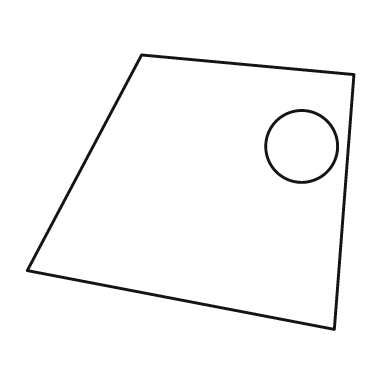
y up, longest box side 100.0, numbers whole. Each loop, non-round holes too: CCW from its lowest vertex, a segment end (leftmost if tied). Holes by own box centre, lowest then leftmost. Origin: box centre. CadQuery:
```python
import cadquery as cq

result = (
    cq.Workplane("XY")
    .moveTo(44.0, -42.0)
    .lineTo(50.0, 36.0)
    .lineTo(-15.0, 42.0)
    .lineTo(-50.0, -24.0)
    .close()
    .moveTo(34.0, 14.0)
    .circle(11.0)
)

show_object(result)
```